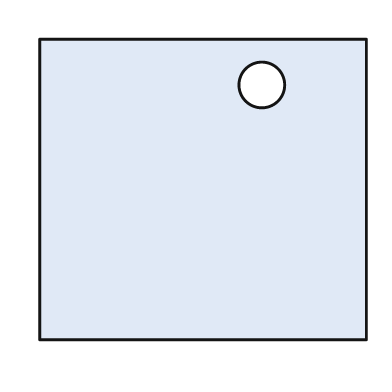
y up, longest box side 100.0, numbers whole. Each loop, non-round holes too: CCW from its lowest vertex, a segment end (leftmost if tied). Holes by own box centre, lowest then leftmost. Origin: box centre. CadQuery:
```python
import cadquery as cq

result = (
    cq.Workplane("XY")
    .moveTo(-50.0, -46.0)
    .lineTo(50.0, -46.0)
    .lineTo(50.0, 46.0)
    .lineTo(-50.0, 46.0)
    .close()
    .moveTo(18.0, 32.0)
    .circle(7.0)
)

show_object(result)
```